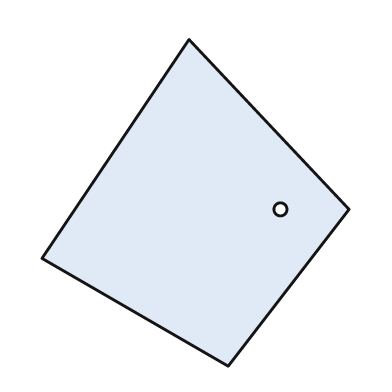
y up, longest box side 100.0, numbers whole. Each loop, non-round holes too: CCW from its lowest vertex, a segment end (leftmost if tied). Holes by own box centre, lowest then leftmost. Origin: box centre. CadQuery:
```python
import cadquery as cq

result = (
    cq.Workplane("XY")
    .moveTo(10.0, -50.0)
    .lineTo(47.0, -2.0)
    .lineTo(-2.0, 50.0)
    .lineTo(-47.0, -17.0)
    .close()
    .moveTo(26.0, -2.0)
    .circle(2.0)
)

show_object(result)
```